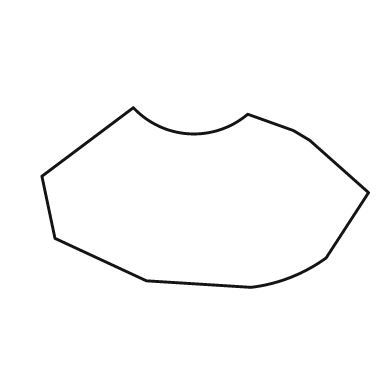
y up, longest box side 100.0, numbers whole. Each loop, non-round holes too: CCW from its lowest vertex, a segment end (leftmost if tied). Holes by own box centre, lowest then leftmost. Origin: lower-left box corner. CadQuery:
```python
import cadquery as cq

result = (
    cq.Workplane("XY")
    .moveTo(64.0, 0.0)
    .threePointArc((76.0, 3.0), (87.0, 9.0))
    .lineTo(100.0, 29.0)
    .lineTo(82.0, 45.0)
    .lineTo(77.0, 48.0)
    .lineTo(63.0, 53.0)
    .threePointArc((45.0, 47.0), (28.0, 55.0))
    .lineTo(0.0, 34.0)
    .lineTo(4.0, 15.0)
    .lineTo(32.0, 2.0)
    .close()
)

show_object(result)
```